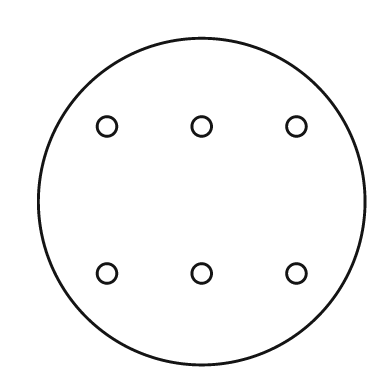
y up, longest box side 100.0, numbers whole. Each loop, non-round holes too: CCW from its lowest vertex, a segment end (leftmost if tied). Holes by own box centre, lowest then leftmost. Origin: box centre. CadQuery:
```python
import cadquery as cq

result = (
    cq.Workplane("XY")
    .moveTo(0.0, 0.0)
    .circle(50.0)
    .moveTo(-29.0, -22.0)
    .circle(3.0)
    .moveTo(0.0, -22.0)
    .circle(3.0)
    .moveTo(29.0, -22.0)
    .circle(3.0)
    .moveTo(-29.0, 23.0)
    .circle(3.0)
    .moveTo(0.0, 23.0)
    .circle(3.0)
    .moveTo(29.0, 23.0)
    .circle(3.0)
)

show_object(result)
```